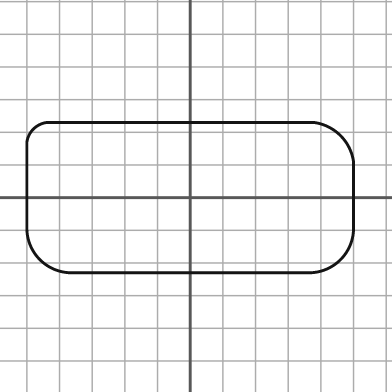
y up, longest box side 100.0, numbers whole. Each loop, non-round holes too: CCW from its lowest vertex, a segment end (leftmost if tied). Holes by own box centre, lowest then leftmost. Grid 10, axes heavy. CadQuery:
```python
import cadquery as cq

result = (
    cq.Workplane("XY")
    .moveTo(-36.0, -23.0)
    .lineTo(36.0, -23.0)
    .threePointArc((46.0, -19.0), (50.0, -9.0))
    .lineTo(50.0, 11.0)
    .threePointArc((46.0, 19.0), (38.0, 23.0))
    .lineTo(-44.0, 23.0)
    .threePointArc((-48.0, 21.0), (-50.0, 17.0))
    .lineTo(-50.0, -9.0)
    .threePointArc((-46.0, -19.0), (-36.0, -23.0))
    .close()
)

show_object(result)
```